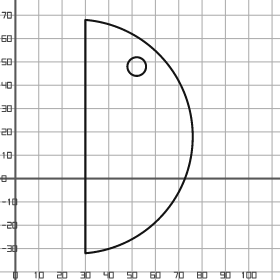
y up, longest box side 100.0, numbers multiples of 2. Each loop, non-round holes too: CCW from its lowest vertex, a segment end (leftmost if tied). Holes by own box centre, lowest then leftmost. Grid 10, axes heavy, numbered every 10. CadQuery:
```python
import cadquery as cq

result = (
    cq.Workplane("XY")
    .moveTo(30.0, -32.0)
    .threePointArc((76.0, 18.0), (30.0, 68.0))
    .close()
    .moveTo(52.0, 48.0)
    .circle(4.0)
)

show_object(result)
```